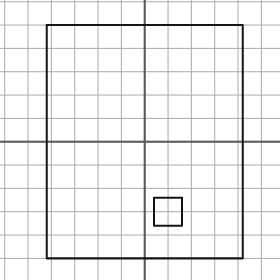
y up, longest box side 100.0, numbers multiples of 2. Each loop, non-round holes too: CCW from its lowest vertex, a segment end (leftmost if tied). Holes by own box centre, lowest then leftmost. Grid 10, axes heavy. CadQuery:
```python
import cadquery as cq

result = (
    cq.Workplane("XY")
    .moveTo(-42.0, -50.0)
    .lineTo(42.0, -50.0)
    .lineTo(42.0, 50.0)
    .lineTo(-42.0, 50.0)
    .close()
    .moveTo(4.0, -36.0)
    .lineTo(16.0, -36.0)
    .lineTo(16.0, -24.0)
    .lineTo(4.0, -24.0)
    .close()
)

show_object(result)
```